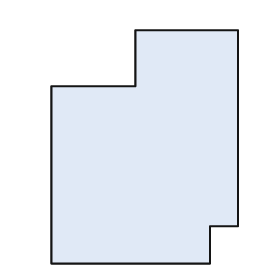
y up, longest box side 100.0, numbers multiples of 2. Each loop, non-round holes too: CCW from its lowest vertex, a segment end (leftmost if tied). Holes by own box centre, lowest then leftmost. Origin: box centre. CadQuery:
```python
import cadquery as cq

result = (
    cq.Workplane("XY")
    .moveTo(-40.0, -50.0)
    .lineTo(28.0, -50.0)
    .lineTo(28.0, -34.0)
    .lineTo(40.0, -34.0)
    .lineTo(40.0, 50.0)
    .lineTo(-4.0, 50.0)
    .lineTo(-4.0, 26.0)
    .lineTo(-40.0, 26.0)
    .close()
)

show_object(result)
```